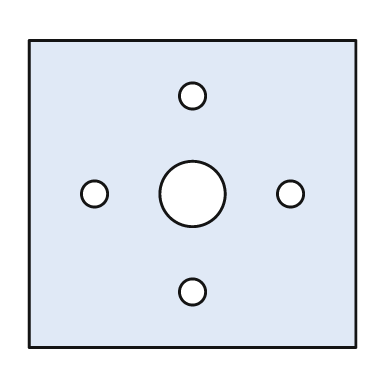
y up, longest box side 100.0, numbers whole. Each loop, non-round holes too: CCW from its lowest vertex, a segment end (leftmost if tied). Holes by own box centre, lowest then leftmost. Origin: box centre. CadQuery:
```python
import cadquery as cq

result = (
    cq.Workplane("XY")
    .moveTo(-50.0, -47.0)
    .lineTo(50.0, -47.0)
    .lineTo(50.0, 47.0)
    .lineTo(-50.0, 47.0)
    .close()
    .moveTo(0.0, -30.0)
    .circle(4.0)
    .moveTo(-30.0, 0.0)
    .circle(4.0)
    .moveTo(0.0, 0.0)
    .circle(10.0)
    .moveTo(30.0, 0.0)
    .circle(4.0)
    .moveTo(0.0, 30.0)
    .circle(4.0)
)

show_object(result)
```